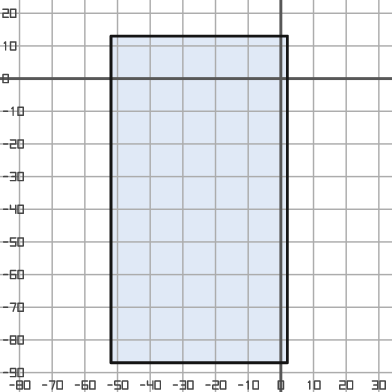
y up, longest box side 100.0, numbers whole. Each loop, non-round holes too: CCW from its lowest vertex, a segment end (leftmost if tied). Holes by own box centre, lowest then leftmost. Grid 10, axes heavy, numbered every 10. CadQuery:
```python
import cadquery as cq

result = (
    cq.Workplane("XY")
    .moveTo(-52.0, -87.0)
    .lineTo(2.0, -87.0)
    .lineTo(2.0, 13.0)
    .lineTo(-52.0, 13.0)
    .close()
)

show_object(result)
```